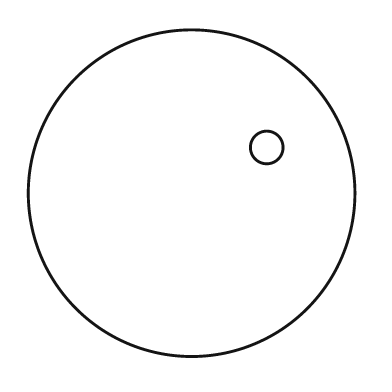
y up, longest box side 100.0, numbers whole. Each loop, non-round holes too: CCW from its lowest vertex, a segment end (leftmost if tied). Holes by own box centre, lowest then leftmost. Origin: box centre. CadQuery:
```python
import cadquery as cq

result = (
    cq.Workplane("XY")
    .moveTo(0.0, 0.0)
    .circle(50.0)
    .moveTo(23.0, 14.0)
    .circle(5.0)
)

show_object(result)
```